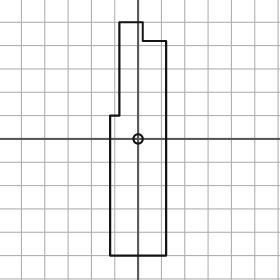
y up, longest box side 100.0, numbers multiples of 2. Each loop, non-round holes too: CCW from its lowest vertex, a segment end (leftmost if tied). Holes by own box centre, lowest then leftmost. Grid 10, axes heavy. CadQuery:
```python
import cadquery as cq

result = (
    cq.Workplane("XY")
    .moveTo(-12.0, -50.0)
    .lineTo(12.0, -50.0)
    .lineTo(12.0, 42.0)
    .lineTo(2.0, 42.0)
    .lineTo(2.0, 50.0)
    .lineTo(-8.0, 50.0)
    .lineTo(-8.0, 10.0)
    .lineTo(-12.0, 10.0)
    .close()
    .moveTo(0.0, 0.0)
    .circle(2.0)
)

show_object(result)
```